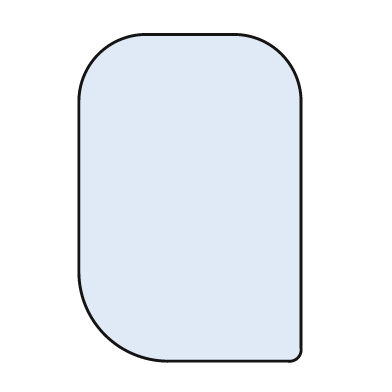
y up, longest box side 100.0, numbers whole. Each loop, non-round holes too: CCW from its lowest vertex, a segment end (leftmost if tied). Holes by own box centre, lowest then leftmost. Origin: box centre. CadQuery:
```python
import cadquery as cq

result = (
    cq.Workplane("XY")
    .moveTo(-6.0, -50.0)
    .lineTo(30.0, -50.0)
    .threePointArc((33.0, -49.0), (34.0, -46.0))
    .lineTo(34.0, 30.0)
    .threePointArc((28.0, 44.0), (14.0, 50.0))
    .lineTo(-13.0, 50.0)
    .threePointArc((-28.0, 44.0), (-34.0, 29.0))
    .lineTo(-34.0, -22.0)
    .threePointArc((-26.0, -42.0), (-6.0, -50.0))
    .close()
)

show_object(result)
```